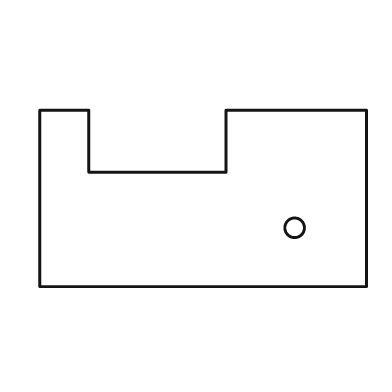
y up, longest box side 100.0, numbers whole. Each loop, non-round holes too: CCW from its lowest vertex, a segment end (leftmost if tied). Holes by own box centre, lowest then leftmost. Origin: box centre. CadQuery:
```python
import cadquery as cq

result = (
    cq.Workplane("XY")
    .moveTo(-50.0, -27.0)
    .lineTo(50.0, -27.0)
    .lineTo(50.0, 27.0)
    .lineTo(7.0, 27.0)
    .lineTo(7.0, 8.0)
    .lineTo(-35.0, 8.0)
    .lineTo(-35.0, 27.0)
    .lineTo(-50.0, 27.0)
    .close()
    .moveTo(28.0, -9.0)
    .circle(3.0)
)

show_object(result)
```